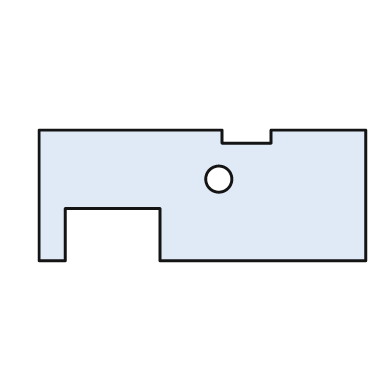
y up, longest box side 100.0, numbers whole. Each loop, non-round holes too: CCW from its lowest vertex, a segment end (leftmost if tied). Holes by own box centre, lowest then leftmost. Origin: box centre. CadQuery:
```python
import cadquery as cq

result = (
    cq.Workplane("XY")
    .moveTo(-50.0, -20.0)
    .lineTo(-42.0, -20.0)
    .lineTo(-42.0, -4.0)
    .lineTo(-13.0, -4.0)
    .lineTo(-13.0, -20.0)
    .lineTo(50.0, -20.0)
    .lineTo(50.0, 20.0)
    .lineTo(21.0, 20.0)
    .lineTo(21.0, 16.0)
    .lineTo(6.0, 16.0)
    .lineTo(6.0, 20.0)
    .lineTo(-50.0, 20.0)
    .close()
    .moveTo(5.0, 5.0)
    .circle(4.0)
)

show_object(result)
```